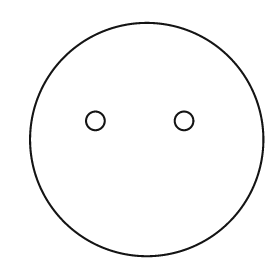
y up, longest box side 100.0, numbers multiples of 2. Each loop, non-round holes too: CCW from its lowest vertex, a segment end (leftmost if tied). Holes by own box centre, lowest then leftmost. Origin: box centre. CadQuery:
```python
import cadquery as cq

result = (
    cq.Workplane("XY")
    .moveTo(0.0, 0.0)
    .circle(50.0)
    .moveTo(-22.0, 8.0)
    .circle(4.0)
    .moveTo(16.0, 8.0)
    .circle(4.0)
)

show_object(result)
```